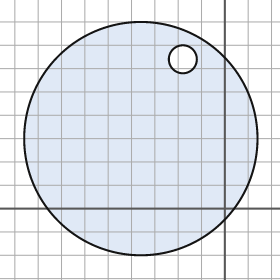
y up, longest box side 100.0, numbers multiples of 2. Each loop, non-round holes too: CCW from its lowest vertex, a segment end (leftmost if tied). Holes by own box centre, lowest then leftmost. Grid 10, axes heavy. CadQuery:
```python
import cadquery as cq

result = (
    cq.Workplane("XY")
    .moveTo(-36.0, 30.0)
    .circle(50.0)
    .moveTo(-18.0, 64.0)
    .circle(6.0)
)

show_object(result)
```